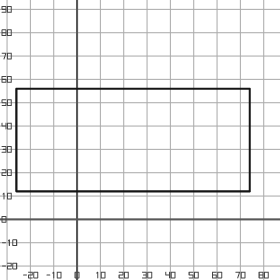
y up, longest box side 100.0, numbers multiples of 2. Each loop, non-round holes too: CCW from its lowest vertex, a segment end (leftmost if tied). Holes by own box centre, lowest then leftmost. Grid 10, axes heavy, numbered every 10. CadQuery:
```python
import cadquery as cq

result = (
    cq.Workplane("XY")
    .moveTo(-26.0, 12.0)
    .lineTo(74.0, 12.0)
    .lineTo(74.0, 56.0)
    .lineTo(-26.0, 56.0)
    .close()
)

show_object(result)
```